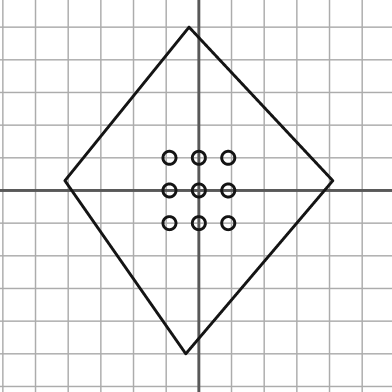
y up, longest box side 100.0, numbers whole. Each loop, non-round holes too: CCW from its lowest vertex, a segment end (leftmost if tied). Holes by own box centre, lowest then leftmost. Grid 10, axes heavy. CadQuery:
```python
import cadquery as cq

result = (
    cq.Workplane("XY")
    .moveTo(-4.0, -50.0)
    .lineTo(41.0, 3.0)
    .lineTo(-3.0, 50.0)
    .lineTo(-41.0, 3.0)
    .close()
    .moveTo(-9.0, -10.0)
    .circle(2.0)
    .moveTo(0.0, -10.0)
    .circle(2.0)
    .moveTo(9.0, -10.0)
    .circle(2.0)
    .moveTo(-9.0, 0.0)
    .circle(2.0)
    .moveTo(0.0, 0.0)
    .circle(2.0)
    .moveTo(9.0, 0.0)
    .circle(2.0)
    .moveTo(-9.0, 10.0)
    .circle(2.0)
    .moveTo(0.0, 10.0)
    .circle(2.0)
    .moveTo(9.0, 10.0)
    .circle(2.0)
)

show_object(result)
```